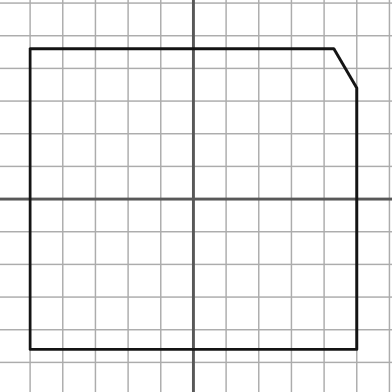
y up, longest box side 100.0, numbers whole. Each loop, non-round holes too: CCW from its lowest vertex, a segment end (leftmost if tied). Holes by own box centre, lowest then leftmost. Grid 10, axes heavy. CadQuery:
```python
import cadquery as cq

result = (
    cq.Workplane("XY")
    .moveTo(-50.0, -46.0)
    .lineTo(50.0, -46.0)
    .lineTo(50.0, 34.0)
    .lineTo(43.0, 46.0)
    .lineTo(-50.0, 46.0)
    .close()
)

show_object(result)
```